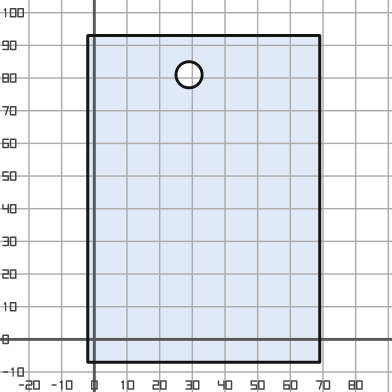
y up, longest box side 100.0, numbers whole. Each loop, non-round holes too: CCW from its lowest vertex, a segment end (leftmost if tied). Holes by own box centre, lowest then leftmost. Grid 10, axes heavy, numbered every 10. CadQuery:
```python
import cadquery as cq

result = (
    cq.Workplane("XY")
    .moveTo(-2.0, -7.0)
    .lineTo(69.0, -7.0)
    .lineTo(69.0, 93.0)
    .lineTo(-2.0, 93.0)
    .close()
    .moveTo(29.0, 81.0)
    .circle(4.0)
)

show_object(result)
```